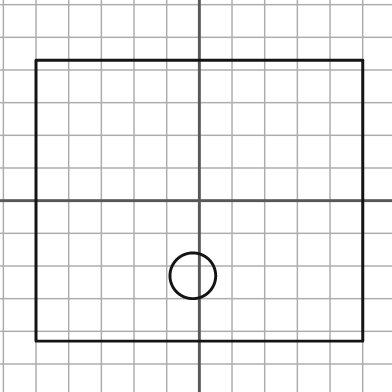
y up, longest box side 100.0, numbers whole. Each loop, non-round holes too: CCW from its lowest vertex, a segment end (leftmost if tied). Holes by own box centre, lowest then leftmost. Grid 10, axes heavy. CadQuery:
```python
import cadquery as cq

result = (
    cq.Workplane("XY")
    .moveTo(-50.0, -43.0)
    .lineTo(50.0, -43.0)
    .lineTo(50.0, 43.0)
    .lineTo(-50.0, 43.0)
    .close()
    .moveTo(-2.0, -23.0)
    .circle(7.0)
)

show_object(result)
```